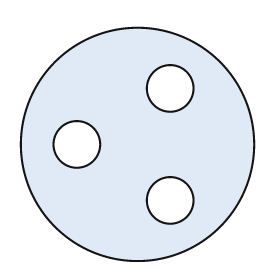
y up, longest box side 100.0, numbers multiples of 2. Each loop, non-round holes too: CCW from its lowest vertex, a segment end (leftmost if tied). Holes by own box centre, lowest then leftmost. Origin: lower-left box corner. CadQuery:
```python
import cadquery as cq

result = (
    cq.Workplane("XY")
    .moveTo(50.0, 50.0)
    .circle(50.0)
    .moveTo(64.0, 26.0)
    .circle(10.0)
    .moveTo(24.0, 50.0)
    .circle(10.0)
    .moveTo(64.0, 74.0)
    .circle(10.0)
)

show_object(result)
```